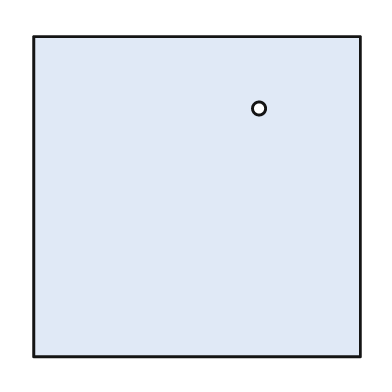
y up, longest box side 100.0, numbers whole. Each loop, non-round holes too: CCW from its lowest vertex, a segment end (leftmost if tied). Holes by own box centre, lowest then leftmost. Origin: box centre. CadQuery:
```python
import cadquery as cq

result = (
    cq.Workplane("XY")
    .moveTo(-50.0, -49.0)
    .lineTo(50.0, -49.0)
    .lineTo(50.0, 49.0)
    .lineTo(-50.0, 49.0)
    .close()
    .moveTo(19.0, 27.0)
    .circle(2.0)
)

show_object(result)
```